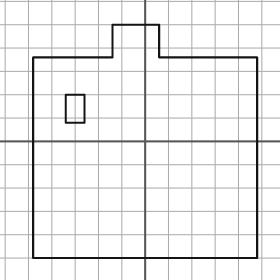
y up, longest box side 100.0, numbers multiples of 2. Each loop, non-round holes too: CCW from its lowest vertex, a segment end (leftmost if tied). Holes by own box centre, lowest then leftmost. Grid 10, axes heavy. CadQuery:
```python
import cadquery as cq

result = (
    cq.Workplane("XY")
    .moveTo(-48.0, -50.0)
    .lineTo(48.0, -50.0)
    .lineTo(48.0, 36.0)
    .lineTo(6.0, 36.0)
    .lineTo(6.0, 50.0)
    .lineTo(-14.0, 50.0)
    .lineTo(-14.0, 36.0)
    .lineTo(-48.0, 36.0)
    .close()
    .moveTo(-34.0, 8.0)
    .lineTo(-26.0, 8.0)
    .lineTo(-26.0, 20.0)
    .lineTo(-34.0, 20.0)
    .close()
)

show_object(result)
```